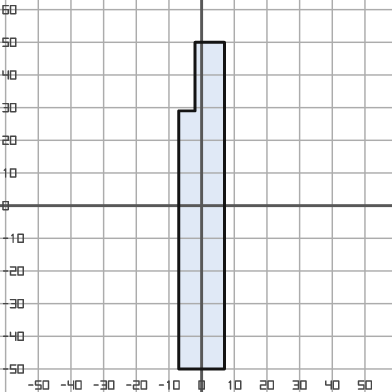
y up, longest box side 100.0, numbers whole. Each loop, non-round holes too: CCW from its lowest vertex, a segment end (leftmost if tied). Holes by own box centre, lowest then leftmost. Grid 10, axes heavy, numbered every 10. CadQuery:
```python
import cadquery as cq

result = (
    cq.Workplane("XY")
    .moveTo(-7.0, -50.0)
    .lineTo(7.0, -50.0)
    .lineTo(7.0, 50.0)
    .lineTo(-2.0, 50.0)
    .lineTo(-2.0, 29.0)
    .lineTo(-7.0, 29.0)
    .close()
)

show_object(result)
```